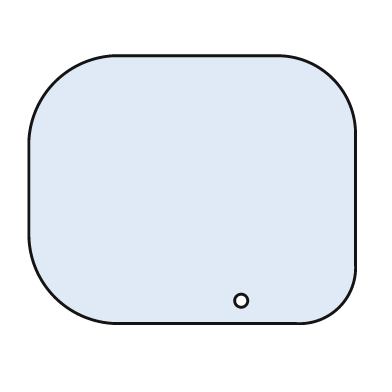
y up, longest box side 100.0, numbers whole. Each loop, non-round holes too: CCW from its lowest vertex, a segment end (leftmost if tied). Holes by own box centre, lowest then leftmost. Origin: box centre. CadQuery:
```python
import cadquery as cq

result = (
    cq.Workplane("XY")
    .moveTo(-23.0, -41.0)
    .lineTo(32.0, -41.0)
    .threePointArc((45.0, -36.0), (50.0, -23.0))
    .lineTo(50.0, 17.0)
    .threePointArc((43.0, 34.0), (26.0, 41.0))
    .lineTo(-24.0, 41.0)
    .threePointArc((-42.0, 33.0), (-50.0, 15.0))
    .lineTo(-50.0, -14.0)
    .threePointArc((-42.0, -33.0), (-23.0, -41.0))
    .close()
    .moveTo(15.0, -34.0)
    .circle(2.0)
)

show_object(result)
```